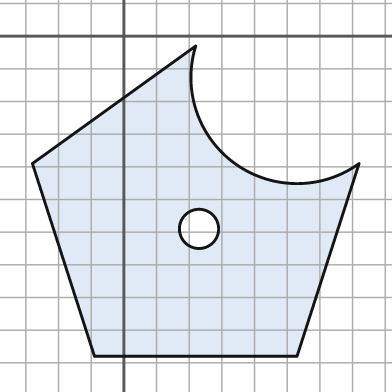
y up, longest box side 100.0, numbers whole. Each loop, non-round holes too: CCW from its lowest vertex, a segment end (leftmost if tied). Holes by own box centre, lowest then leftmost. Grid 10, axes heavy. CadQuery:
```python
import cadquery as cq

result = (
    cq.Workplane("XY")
    .moveTo(-9.0, -98.0)
    .lineTo(53.0, -98.0)
    .lineTo(72.0, -39.0)
    .threePointArc((34.0, -39.0), (22.0, -3.0))
    .lineTo(-28.0, -39.0)
    .close()
    .moveTo(23.0, -59.0)
    .circle(6.0)
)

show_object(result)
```